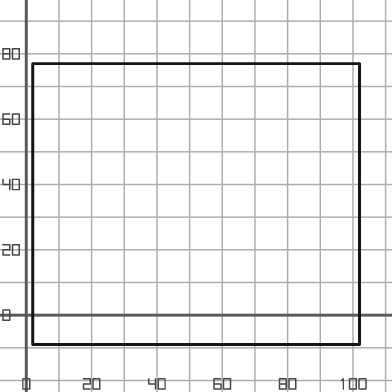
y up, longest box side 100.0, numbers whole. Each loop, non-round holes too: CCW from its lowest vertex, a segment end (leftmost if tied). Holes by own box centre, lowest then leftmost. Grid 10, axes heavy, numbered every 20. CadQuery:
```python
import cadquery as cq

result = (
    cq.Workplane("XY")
    .moveTo(2.0, -9.0)
    .lineTo(102.0, -9.0)
    .lineTo(102.0, 77.0)
    .lineTo(2.0, 77.0)
    .close()
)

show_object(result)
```